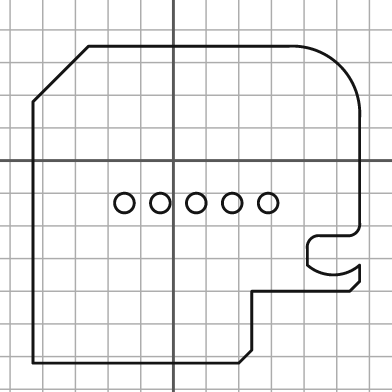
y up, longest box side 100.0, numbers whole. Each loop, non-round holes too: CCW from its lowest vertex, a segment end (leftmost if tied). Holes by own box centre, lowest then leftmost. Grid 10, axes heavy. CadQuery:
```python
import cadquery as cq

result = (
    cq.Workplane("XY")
    .moveTo(-43.0, -62.0)
    .lineTo(20.0, -62.0)
    .lineTo(24.0, -58.0)
    .lineTo(24.0, -40.0)
    .lineTo(54.0, -40.0)
    .lineTo(57.0, -37.0)
    .lineTo(57.0, -32.0)
    .threePointArc((49.0, -35.0), (41.0, -32.0))
    .lineTo(41.0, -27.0)
    .threePointArc((42.0, -24.0), (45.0, -23.0))
    .lineTo(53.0, -23.0)
    .threePointArc((56.0, -22.0), (57.0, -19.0))
    .lineTo(57.0, 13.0)
    .threePointArc((51.0, 29.0), (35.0, 35.0))
    .lineTo(-26.0, 35.0)
    .lineTo(-43.0, 18.0)
    .close()
    .moveTo(-15.0, -13.0)
    .circle(3.0)
    .moveTo(-4.0, -13.0)
    .circle(3.0)
    .moveTo(7.0, -13.0)
    .circle(3.0)
    .moveTo(18.0, -13.0)
    .circle(3.0)
    .moveTo(29.0, -13.0)
    .circle(3.0)
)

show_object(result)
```